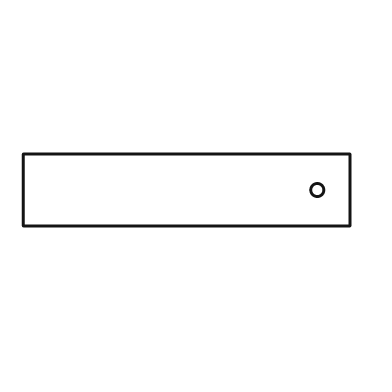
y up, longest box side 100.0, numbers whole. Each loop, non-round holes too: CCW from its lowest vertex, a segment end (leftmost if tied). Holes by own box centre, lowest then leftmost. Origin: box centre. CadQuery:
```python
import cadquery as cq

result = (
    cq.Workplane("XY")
    .moveTo(-50.0, -11.0)
    .lineTo(50.0, -11.0)
    .lineTo(50.0, 11.0)
    .lineTo(-50.0, 11.0)
    .close()
    .moveTo(40.0, 0.0)
    .circle(2.0)
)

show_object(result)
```